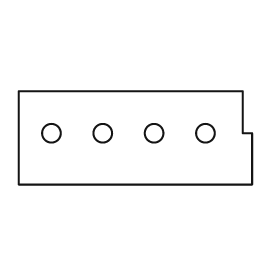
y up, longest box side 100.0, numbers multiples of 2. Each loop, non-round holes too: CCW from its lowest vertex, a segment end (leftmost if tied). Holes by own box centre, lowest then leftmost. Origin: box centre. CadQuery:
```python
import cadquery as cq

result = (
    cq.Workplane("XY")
    .moveTo(-50.0, -20.0)
    .lineTo(50.0, -20.0)
    .lineTo(50.0, 2.0)
    .lineTo(46.0, 2.0)
    .lineTo(46.0, 20.0)
    .lineTo(-50.0, 20.0)
    .close()
    .moveTo(-36.0, 2.0)
    .circle(4.0)
    .moveTo(-14.0, 2.0)
    .circle(4.0)
    .moveTo(8.0, 2.0)
    .circle(4.0)
    .moveTo(30.0, 2.0)
    .circle(4.0)
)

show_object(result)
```